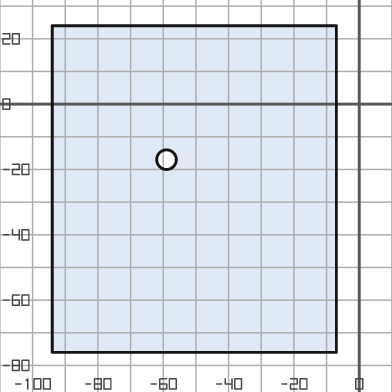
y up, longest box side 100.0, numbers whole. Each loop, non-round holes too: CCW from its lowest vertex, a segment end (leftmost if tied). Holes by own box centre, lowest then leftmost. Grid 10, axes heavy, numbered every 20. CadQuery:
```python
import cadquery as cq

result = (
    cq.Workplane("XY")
    .moveTo(-94.0, -76.0)
    .lineTo(-7.0, -76.0)
    .lineTo(-7.0, 24.0)
    .lineTo(-94.0, 24.0)
    .close()
    .moveTo(-59.0, -17.0)
    .circle(3.0)
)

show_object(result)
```